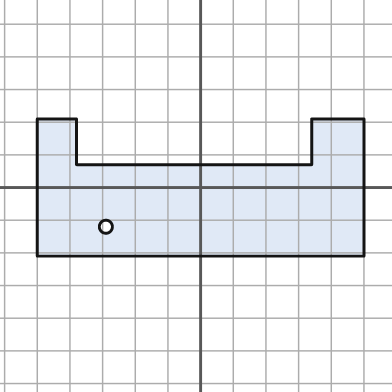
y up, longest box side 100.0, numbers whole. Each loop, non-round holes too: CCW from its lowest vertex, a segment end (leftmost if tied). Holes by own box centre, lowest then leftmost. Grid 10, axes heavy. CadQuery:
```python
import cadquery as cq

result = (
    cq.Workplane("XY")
    .moveTo(-50.0, -21.0)
    .lineTo(50.0, -21.0)
    .lineTo(50.0, 21.0)
    .lineTo(34.0, 21.0)
    .lineTo(34.0, 7.0)
    .lineTo(-38.0, 7.0)
    .lineTo(-38.0, 21.0)
    .lineTo(-50.0, 21.0)
    .close()
    .moveTo(-29.0, -12.0)
    .circle(2.0)
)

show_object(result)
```